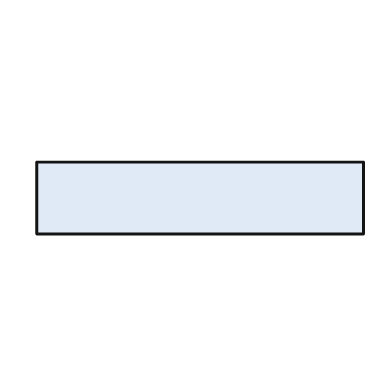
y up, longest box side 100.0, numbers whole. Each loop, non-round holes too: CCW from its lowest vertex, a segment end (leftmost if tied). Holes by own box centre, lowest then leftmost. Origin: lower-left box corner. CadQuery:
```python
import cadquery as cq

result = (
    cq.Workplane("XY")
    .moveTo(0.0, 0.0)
    .lineTo(100.0, 0.0)
    .lineTo(100.0, 22.0)
    .lineTo(0.0, 22.0)
    .close()
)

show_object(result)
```